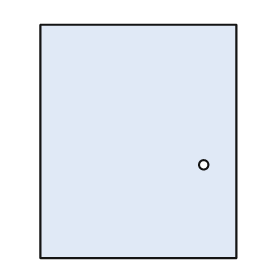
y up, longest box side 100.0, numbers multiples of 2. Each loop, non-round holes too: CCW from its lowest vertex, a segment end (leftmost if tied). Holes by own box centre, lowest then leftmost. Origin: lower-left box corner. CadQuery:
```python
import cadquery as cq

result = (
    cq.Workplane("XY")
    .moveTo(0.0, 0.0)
    .lineTo(84.0, 0.0)
    .lineTo(84.0, 100.0)
    .lineTo(0.0, 100.0)
    .close()
    .moveTo(70.0, 40.0)
    .circle(2.0)
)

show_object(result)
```